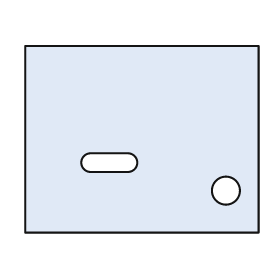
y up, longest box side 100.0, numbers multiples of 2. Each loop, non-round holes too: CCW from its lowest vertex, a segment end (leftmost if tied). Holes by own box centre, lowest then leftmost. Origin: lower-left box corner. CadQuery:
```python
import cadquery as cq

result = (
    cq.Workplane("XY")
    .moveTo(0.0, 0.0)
    .lineTo(100.0, 0.0)
    .lineTo(100.0, 80.0)
    .lineTo(0.0, 80.0)
    .close()
    .moveTo(86.0, 18.0)
    .circle(6.0)
    .moveTo(28.0, 26.0)
    .lineTo(44.0, 26.0)
    .threePointArc((48.0, 30.0), (44.0, 34.0))
    .lineTo(28.0, 34.0)
    .threePointArc((24.0, 30.0), (28.0, 26.0))
    .close()
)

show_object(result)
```